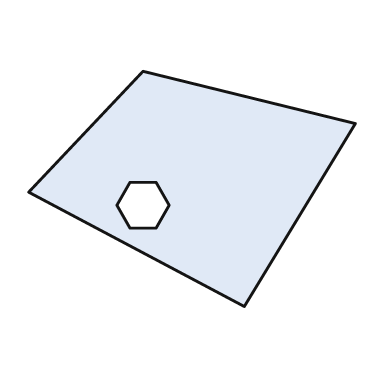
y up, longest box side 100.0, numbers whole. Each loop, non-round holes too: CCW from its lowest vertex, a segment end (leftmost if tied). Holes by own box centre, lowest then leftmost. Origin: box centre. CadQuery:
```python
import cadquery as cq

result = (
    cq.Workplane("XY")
    .moveTo(16.0, -36.0)
    .lineTo(50.0, 20.0)
    .lineTo(-15.0, 36.0)
    .lineTo(-50.0, -1.0)
    .close()
    .moveTo(-19.0, -12.0)
    .lineTo(-11.0, -12.0)
    .lineTo(-7.0, -5.0)
    .lineTo(-11.0, 2.0)
    .lineTo(-19.0, 2.0)
    .lineTo(-23.0, -5.0)
    .close()
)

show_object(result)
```